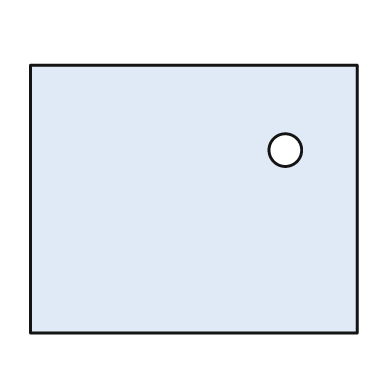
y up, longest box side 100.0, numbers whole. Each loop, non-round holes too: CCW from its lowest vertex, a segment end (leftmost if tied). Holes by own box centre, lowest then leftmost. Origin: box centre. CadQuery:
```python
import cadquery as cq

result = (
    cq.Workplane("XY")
    .moveTo(-50.0, -41.0)
    .lineTo(50.0, -41.0)
    .lineTo(50.0, 41.0)
    .lineTo(-50.0, 41.0)
    .close()
    .moveTo(28.0, 15.0)
    .circle(5.0)
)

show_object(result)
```